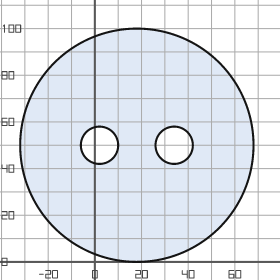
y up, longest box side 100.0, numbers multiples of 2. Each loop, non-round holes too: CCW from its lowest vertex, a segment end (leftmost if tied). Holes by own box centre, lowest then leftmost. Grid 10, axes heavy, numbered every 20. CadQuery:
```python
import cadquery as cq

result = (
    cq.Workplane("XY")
    .moveTo(18.0, 50.0)
    .circle(50.0)
    .moveTo(2.0, 50.0)
    .circle(8.0)
    .moveTo(34.0, 50.0)
    .circle(8.0)
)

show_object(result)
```